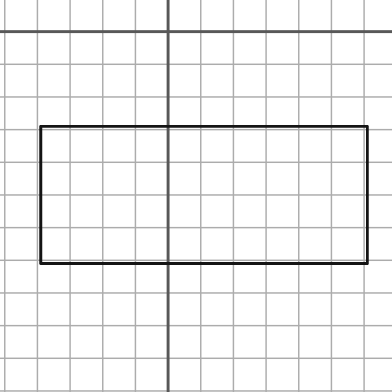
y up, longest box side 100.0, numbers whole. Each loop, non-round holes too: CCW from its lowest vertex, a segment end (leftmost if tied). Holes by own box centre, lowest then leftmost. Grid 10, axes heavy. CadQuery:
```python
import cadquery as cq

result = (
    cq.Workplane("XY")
    .moveTo(-39.0, -71.0)
    .lineTo(61.0, -71.0)
    .lineTo(61.0, -29.0)
    .lineTo(-39.0, -29.0)
    .close()
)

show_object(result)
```